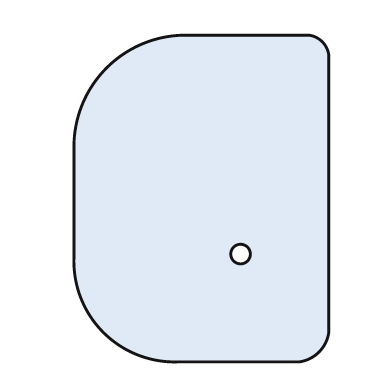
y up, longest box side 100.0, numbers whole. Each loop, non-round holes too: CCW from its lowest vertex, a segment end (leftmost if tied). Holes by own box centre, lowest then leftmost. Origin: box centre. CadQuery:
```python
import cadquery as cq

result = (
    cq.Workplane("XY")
    .moveTo(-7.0, -50.0)
    .lineTo(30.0, -50.0)
    .threePointArc((36.0, -47.0), (39.0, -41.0))
    .lineTo(39.0, 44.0)
    .threePointArc((37.0, 48.0), (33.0, 50.0))
    .lineTo(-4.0, 50.0)
    .threePointArc((-29.0, 40.0), (-39.0, 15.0))
    .lineTo(-39.0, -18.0)
    .threePointArc((-30.0, -41.0), (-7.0, -50.0))
    .close()
    .moveTo(12.0, -17.0)
    .circle(3.0)
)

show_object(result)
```